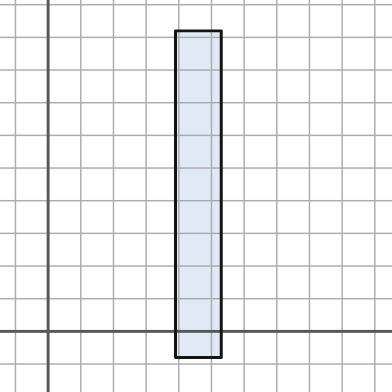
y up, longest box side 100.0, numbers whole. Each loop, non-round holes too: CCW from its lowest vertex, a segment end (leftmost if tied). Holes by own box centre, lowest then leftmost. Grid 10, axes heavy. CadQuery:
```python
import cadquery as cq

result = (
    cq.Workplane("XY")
    .moveTo(39.0, -8.0)
    .lineTo(53.0, -8.0)
    .lineTo(53.0, 92.0)
    .lineTo(39.0, 92.0)
    .close()
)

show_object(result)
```